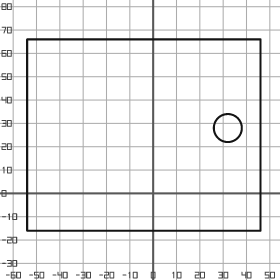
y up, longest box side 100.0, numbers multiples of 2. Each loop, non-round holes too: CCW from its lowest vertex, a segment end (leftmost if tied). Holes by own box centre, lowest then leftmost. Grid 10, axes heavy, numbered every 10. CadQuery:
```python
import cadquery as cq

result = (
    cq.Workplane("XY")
    .moveTo(-54.0, -16.0)
    .lineTo(46.0, -16.0)
    .lineTo(46.0, 66.0)
    .lineTo(-54.0, 66.0)
    .close()
    .moveTo(32.0, 28.0)
    .circle(6.0)
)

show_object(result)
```